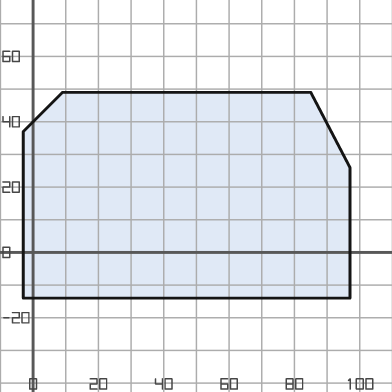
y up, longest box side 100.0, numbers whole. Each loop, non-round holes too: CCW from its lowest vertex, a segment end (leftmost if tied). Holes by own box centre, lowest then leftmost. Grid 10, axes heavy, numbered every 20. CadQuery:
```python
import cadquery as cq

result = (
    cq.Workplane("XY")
    .moveTo(-3.0, -14.0)
    .lineTo(97.0, -14.0)
    .lineTo(97.0, 26.0)
    .lineTo(85.0, 49.0)
    .lineTo(9.0, 49.0)
    .lineTo(-3.0, 37.0)
    .close()
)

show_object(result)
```